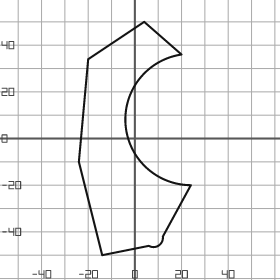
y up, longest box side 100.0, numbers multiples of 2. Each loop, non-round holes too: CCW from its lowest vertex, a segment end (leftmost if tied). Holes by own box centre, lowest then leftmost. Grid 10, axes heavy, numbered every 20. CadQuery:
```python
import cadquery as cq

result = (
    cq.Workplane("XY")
    .moveTo(-14.0, -50.0)
    .lineTo(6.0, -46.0)
    .threePointArc((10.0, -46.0), (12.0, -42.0))
    .lineTo(24.0, -20.0)
    .threePointArc((-4.0, 6.0), (20.0, 36.0))
    .lineTo(4.0, 50.0)
    .lineTo(-20.0, 34.0)
    .lineTo(-24.0, -10.0)
    .close()
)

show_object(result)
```